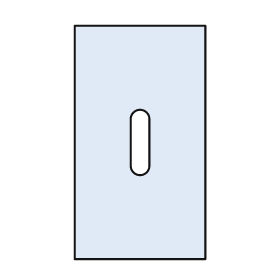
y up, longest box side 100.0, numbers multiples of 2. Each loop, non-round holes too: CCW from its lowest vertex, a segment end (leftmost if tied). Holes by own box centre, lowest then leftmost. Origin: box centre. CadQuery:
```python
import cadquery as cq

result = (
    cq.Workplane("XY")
    .moveTo(-28.0, -50.0)
    .lineTo(28.0, -50.0)
    .lineTo(28.0, 50.0)
    .lineTo(-28.0, 50.0)
    .close()
    .moveTo(-4.0, -10.0)
    .threePointArc((0.0, -14.0), (4.0, -10.0))
    .lineTo(4.0, 10.0)
    .threePointArc((0.0, 14.0), (-4.0, 10.0))
    .close()
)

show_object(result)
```